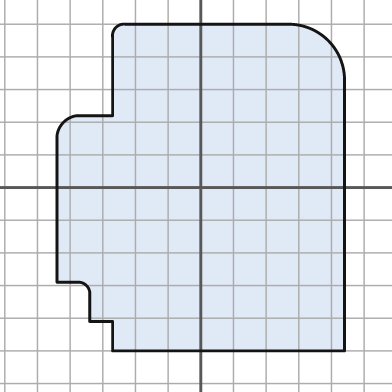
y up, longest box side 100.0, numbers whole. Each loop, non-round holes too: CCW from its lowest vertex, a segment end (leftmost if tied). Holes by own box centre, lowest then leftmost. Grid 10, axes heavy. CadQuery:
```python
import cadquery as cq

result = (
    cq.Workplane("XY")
    .moveTo(-27.0, -50.0)
    .lineTo(44.0, -50.0)
    .lineTo(44.0, 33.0)
    .threePointArc((39.0, 45.0), (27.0, 50.0))
    .lineTo(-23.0, 50.0)
    .threePointArc((-26.0, 49.0), (-27.0, 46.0))
    .lineTo(-27.0, 22.0)
    .lineTo(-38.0, 22.0)
    .threePointArc((-42.0, 20.0), (-44.0, 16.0))
    .lineTo(-44.0, -29.0)
    .lineTo(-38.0, -29.0)
    .threePointArc((-35.0, -30.0), (-34.0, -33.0))
    .lineTo(-34.0, -41.0)
    .lineTo(-27.0, -41.0)
    .close()
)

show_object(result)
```